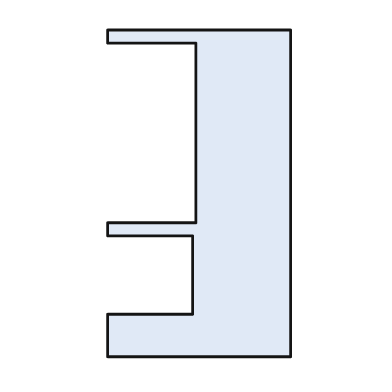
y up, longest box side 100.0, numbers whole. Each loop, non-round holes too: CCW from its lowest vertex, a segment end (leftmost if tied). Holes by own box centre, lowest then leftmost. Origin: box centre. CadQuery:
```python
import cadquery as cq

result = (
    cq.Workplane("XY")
    .moveTo(-28.0, -50.0)
    .lineTo(28.0, -50.0)
    .lineTo(28.0, 50.0)
    .lineTo(-28.0, 50.0)
    .lineTo(-28.0, 46.0)
    .lineTo(-1.0, 46.0)
    .lineTo(-1.0, -9.0)
    .lineTo(-28.0, -9.0)
    .lineTo(-28.0, -13.0)
    .lineTo(-2.0, -13.0)
    .lineTo(-2.0, -37.0)
    .lineTo(-28.0, -37.0)
    .close()
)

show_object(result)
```